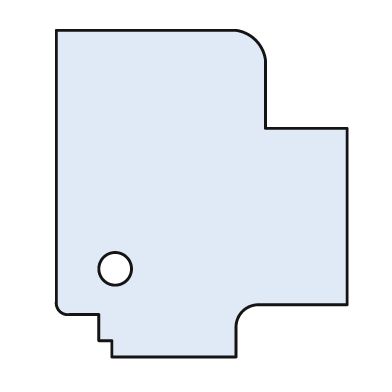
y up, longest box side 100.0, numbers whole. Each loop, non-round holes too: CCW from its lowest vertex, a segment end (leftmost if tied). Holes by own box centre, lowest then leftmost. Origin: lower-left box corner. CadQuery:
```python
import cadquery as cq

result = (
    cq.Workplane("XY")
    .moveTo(17.0, 0.0)
    .lineTo(55.0, 0.0)
    .lineTo(55.0, 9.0)
    .threePointArc((57.0, 14.0), (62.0, 16.0))
    .lineTo(89.0, 16.0)
    .lineTo(89.0, 70.0)
    .lineTo(64.0, 70.0)
    .lineTo(64.0, 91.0)
    .threePointArc((61.0, 97.0), (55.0, 100.0))
    .lineTo(0.0, 100.0)
    .lineTo(0.0, 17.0)
    .threePointArc((1.0, 14.0), (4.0, 13.0))
    .lineTo(13.0, 13.0)
    .lineTo(13.0, 5.0)
    .lineTo(17.0, 5.0)
    .close()
    .moveTo(18.0, 27.0)
    .circle(5.0)
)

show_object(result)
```